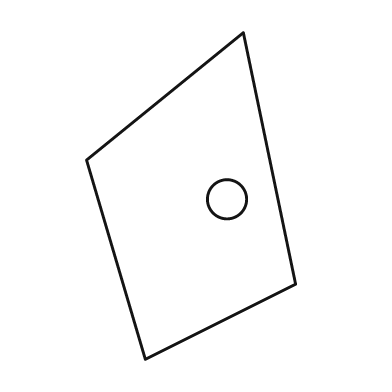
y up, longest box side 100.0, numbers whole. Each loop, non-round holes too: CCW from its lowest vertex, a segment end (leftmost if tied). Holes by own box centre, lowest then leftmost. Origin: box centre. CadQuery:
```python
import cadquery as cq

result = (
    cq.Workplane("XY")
    .moveTo(-14.0, -50.0)
    .lineTo(32.0, -27.0)
    .lineTo(16.0, 50.0)
    .lineTo(-32.0, 11.0)
    .close()
    .moveTo(11.0, -1.0)
    .circle(6.0)
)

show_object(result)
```